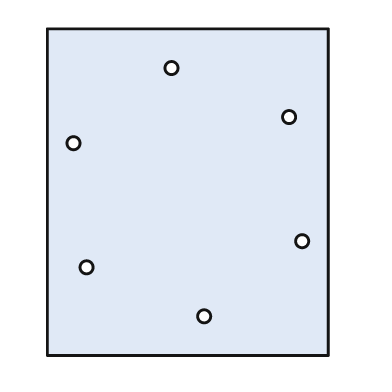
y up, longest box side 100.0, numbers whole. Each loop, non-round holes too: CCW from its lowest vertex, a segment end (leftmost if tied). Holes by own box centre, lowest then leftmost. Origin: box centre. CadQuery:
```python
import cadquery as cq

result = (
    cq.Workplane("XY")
    .moveTo(-43.0, -50.0)
    .lineTo(43.0, -50.0)
    .lineTo(43.0, 50.0)
    .lineTo(-43.0, 50.0)
    .close()
    .moveTo(5.0, -38.0)
    .circle(2.0)
    .moveTo(-31.0, -23.0)
    .circle(2.0)
    .moveTo(35.0, -15.0)
    .circle(2.0)
    .moveTo(-35.0, 15.0)
    .circle(2.0)
    .moveTo(31.0, 23.0)
    .circle(2.0)
    .moveTo(-5.0, 38.0)
    .circle(2.0)
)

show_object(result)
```